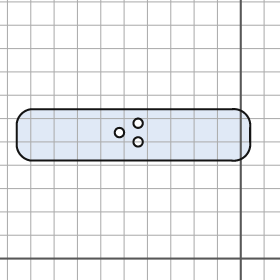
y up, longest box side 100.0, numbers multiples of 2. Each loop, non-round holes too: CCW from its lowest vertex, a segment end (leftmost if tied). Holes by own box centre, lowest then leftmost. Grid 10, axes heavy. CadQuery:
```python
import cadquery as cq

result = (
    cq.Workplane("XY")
    .moveTo(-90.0, 42.0)
    .lineTo(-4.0, 42.0)
    .threePointArc((2.0, 44.0), (4.0, 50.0))
    .lineTo(4.0, 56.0)
    .threePointArc((2.0, 62.0), (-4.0, 64.0))
    .lineTo(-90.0, 64.0)
    .threePointArc((-94.0, 62.0), (-96.0, 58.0))
    .lineTo(-96.0, 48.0)
    .threePointArc((-94.0, 44.0), (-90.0, 42.0))
    .close()
    .moveTo(-44.0, 50.0)
    .circle(2.0)
    .moveTo(-52.0, 54.0)
    .circle(2.0)
    .moveTo(-44.0, 58.0)
    .circle(2.0)
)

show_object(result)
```